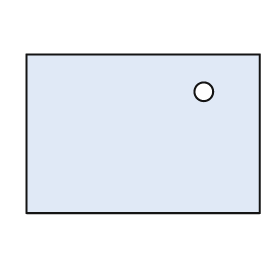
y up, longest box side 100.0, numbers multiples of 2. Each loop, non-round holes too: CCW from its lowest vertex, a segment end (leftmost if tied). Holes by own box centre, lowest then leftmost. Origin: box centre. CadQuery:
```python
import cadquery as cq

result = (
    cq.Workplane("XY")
    .moveTo(-50.0, -34.0)
    .lineTo(50.0, -34.0)
    .lineTo(50.0, 34.0)
    .lineTo(-50.0, 34.0)
    .close()
    .moveTo(26.0, 18.0)
    .circle(4.0)
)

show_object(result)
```